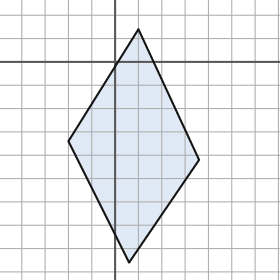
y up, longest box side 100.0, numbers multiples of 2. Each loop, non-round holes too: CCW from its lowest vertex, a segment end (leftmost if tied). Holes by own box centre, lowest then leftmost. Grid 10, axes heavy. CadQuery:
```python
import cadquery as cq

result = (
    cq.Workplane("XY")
    .moveTo(6.0, -86.0)
    .lineTo(36.0, -42.0)
    .lineTo(10.0, 14.0)
    .lineTo(-20.0, -34.0)
    .close()
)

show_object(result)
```